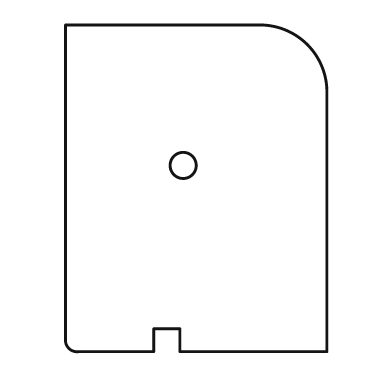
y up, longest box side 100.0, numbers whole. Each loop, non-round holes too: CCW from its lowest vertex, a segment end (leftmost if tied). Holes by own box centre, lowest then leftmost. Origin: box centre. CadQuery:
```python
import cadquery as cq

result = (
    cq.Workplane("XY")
    .moveTo(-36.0, -50.0)
    .lineTo(-13.0, -50.0)
    .lineTo(-13.0, -43.0)
    .lineTo(-5.0, -43.0)
    .lineTo(-5.0, -50.0)
    .lineTo(40.0, -50.0)
    .lineTo(40.0, 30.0)
    .threePointArc((34.0, 44.0), (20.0, 50.0))
    .lineTo(-40.0, 50.0)
    .lineTo(-40.0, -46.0)
    .threePointArc((-39.0, -49.0), (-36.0, -50.0))
    .close()
    .moveTo(-4.0, 7.0)
    .circle(4.0)
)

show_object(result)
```